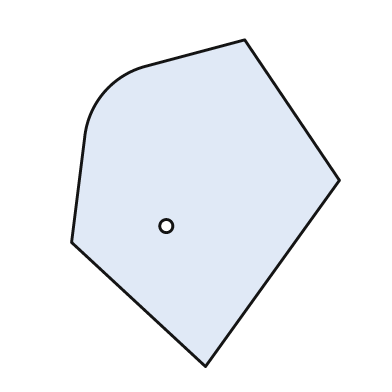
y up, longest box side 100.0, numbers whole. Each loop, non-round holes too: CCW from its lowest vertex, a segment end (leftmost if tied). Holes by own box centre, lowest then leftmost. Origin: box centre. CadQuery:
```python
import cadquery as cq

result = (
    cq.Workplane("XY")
    .moveTo(0.0, -50.0)
    .lineTo(41.0, 7.0)
    .lineTo(12.0, 50.0)
    .lineTo(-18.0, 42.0)
    .threePointArc((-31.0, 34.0), (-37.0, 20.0))
    .lineTo(-41.0, -12.0)
    .close()
    .moveTo(-12.0, -7.0)
    .circle(2.0)
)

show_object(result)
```